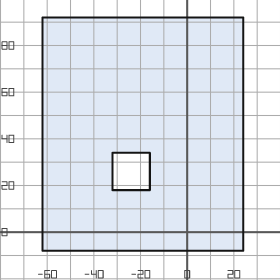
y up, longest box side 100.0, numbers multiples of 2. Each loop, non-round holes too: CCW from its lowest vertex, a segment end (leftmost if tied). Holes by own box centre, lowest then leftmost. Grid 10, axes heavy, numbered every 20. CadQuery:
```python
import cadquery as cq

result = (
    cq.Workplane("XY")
    .moveTo(-62.0, -8.0)
    .lineTo(24.0, -8.0)
    .lineTo(24.0, 92.0)
    .lineTo(-62.0, 92.0)
    .close()
    .moveTo(-32.0, 18.0)
    .lineTo(-16.0, 18.0)
    .lineTo(-16.0, 34.0)
    .lineTo(-32.0, 34.0)
    .close()
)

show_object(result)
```